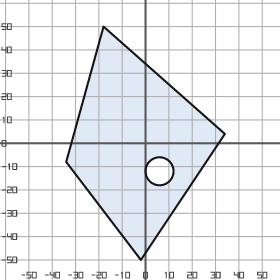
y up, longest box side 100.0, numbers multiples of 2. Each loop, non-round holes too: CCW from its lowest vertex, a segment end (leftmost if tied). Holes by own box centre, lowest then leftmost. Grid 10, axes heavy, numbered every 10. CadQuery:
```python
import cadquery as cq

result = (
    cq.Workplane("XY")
    .moveTo(-2.0, -50.0)
    .lineTo(34.0, 4.0)
    .lineTo(-18.0, 50.0)
    .lineTo(-34.0, -8.0)
    .close()
    .moveTo(6.0, -12.0)
    .circle(6.0)
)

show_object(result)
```